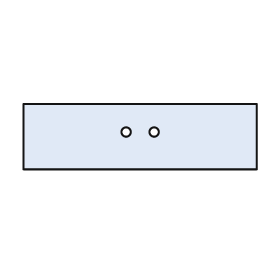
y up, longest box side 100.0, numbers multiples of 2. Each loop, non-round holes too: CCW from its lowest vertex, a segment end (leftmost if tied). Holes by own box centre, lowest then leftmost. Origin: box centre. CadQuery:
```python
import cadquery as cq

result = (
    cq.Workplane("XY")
    .moveTo(-50.0, -14.0)
    .lineTo(50.0, -14.0)
    .lineTo(50.0, 14.0)
    .lineTo(-50.0, 14.0)
    .close()
    .moveTo(-6.0, 2.0)
    .circle(2.0)
    .moveTo(6.0, 2.0)
    .circle(2.0)
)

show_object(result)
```